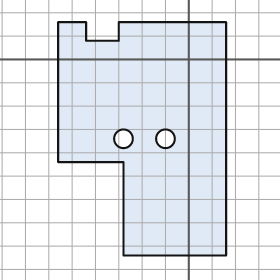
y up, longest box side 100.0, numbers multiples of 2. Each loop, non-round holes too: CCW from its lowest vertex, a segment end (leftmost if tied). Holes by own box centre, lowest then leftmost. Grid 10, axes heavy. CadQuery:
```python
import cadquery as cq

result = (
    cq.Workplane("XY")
    .moveTo(-28.0, -84.0)
    .lineTo(16.0, -84.0)
    .lineTo(16.0, 16.0)
    .lineTo(-30.0, 16.0)
    .lineTo(-30.0, 8.0)
    .lineTo(-44.0, 8.0)
    .lineTo(-44.0, 16.0)
    .lineTo(-56.0, 16.0)
    .lineTo(-56.0, -44.0)
    .lineTo(-28.0, -44.0)
    .close()
    .moveTo(-28.0, -34.0)
    .circle(4.0)
    .moveTo(-10.0, -34.0)
    .circle(4.0)
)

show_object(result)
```